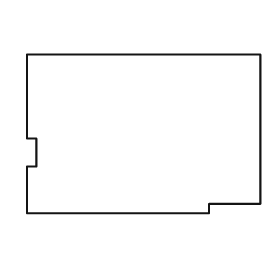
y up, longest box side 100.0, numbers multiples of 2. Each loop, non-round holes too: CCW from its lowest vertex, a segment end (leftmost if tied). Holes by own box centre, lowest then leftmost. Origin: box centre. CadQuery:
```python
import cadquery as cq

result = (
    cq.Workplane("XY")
    .moveTo(-50.0, -34.0)
    .lineTo(28.0, -34.0)
    .lineTo(28.0, -30.0)
    .lineTo(50.0, -30.0)
    .lineTo(50.0, 34.0)
    .lineTo(-50.0, 34.0)
    .lineTo(-50.0, -2.0)
    .lineTo(-46.0, -2.0)
    .lineTo(-46.0, -14.0)
    .lineTo(-50.0, -14.0)
    .close()
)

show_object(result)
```